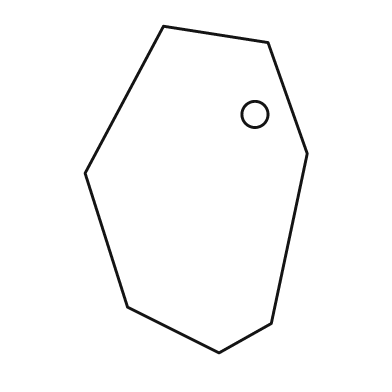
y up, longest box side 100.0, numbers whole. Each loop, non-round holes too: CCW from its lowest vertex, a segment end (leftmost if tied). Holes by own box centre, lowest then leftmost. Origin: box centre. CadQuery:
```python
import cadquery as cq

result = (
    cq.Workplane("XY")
    .moveTo(7.0, -50.0)
    .lineTo(23.0, -41.0)
    .lineTo(34.0, 11.0)
    .lineTo(22.0, 45.0)
    .lineTo(-10.0, 50.0)
    .lineTo(-34.0, 5.0)
    .lineTo(-21.0, -36.0)
    .close()
    .moveTo(18.0, 23.0)
    .circle(4.0)
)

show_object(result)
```